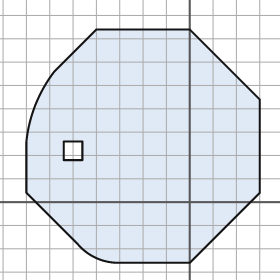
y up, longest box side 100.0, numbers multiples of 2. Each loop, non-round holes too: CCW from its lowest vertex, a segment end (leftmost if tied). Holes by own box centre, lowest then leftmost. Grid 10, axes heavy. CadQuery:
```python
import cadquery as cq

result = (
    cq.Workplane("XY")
    .moveTo(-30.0, -26.0)
    .lineTo(0.0, -26.0)
    .lineTo(30.0, 4.0)
    .lineTo(30.0, 44.0)
    .lineTo(0.0, 74.0)
    .lineTo(-40.0, 74.0)
    .lineTo(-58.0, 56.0)
    .threePointArc((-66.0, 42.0), (-70.0, 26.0))
    .lineTo(-70.0, 4.0)
    .lineTo(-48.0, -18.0)
    .threePointArc((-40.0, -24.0), (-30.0, -26.0))
    .close()
    .moveTo(-54.0, 18.0)
    .lineTo(-46.0, 18.0)
    .lineTo(-46.0, 26.0)
    .lineTo(-54.0, 26.0)
    .close()
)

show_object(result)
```